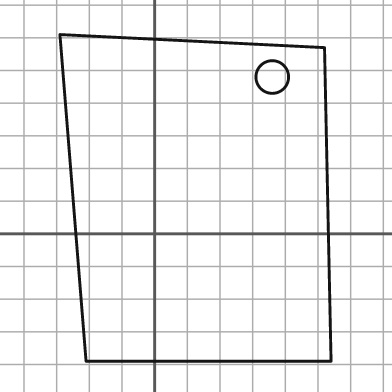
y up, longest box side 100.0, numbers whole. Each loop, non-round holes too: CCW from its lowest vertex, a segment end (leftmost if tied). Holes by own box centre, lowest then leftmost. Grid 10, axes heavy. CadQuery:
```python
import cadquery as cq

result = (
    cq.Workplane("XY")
    .moveTo(-21.0, -39.0)
    .lineTo(54.0, -39.0)
    .lineTo(52.0, 57.0)
    .lineTo(-29.0, 61.0)
    .close()
    .moveTo(36.0, 48.0)
    .circle(5.0)
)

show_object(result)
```